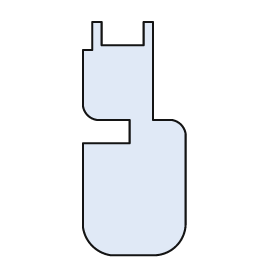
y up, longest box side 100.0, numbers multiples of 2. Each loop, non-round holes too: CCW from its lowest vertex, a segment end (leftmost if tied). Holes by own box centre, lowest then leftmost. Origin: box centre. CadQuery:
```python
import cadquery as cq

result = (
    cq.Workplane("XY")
    .moveTo(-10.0, -50.0)
    .lineTo(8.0, -50.0)
    .threePointArc((18.0, -46.0), (22.0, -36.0))
    .lineTo(22.0, 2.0)
    .threePointArc((20.0, 6.0), (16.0, 8.0))
    .lineTo(8.0, 8.0)
    .lineTo(8.0, 50.0)
    .lineTo(4.0, 50.0)
    .lineTo(4.0, 40.0)
    .lineTo(-14.0, 40.0)
    .lineTo(-14.0, 50.0)
    .lineTo(-18.0, 50.0)
    .lineTo(-18.0, 38.0)
    .lineTo(-22.0, 38.0)
    .lineTo(-22.0, 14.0)
    .threePointArc((-20.0, 10.0), (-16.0, 8.0))
    .lineTo(-2.0, 8.0)
    .lineTo(-2.0, -2.0)
    .lineTo(-22.0, -2.0)
    .lineTo(-22.0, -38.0)
    .threePointArc((-18.0, -46.0), (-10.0, -50.0))
    .close()
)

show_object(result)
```